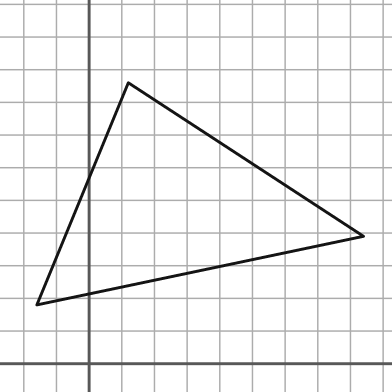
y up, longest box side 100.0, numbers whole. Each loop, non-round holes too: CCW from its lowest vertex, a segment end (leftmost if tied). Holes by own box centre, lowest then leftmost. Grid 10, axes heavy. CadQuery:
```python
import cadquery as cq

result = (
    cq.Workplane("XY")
    .moveTo(-16.0, 18.0)
    .lineTo(84.0, 39.0)
    .lineTo(12.0, 86.0)
    .close()
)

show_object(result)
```